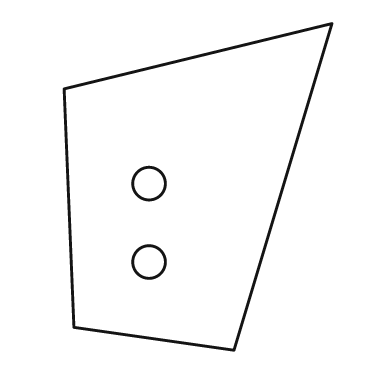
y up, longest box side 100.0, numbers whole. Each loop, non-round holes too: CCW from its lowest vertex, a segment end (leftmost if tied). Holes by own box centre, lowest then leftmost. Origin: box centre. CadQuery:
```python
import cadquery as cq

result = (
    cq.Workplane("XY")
    .moveTo(11.0, -50.0)
    .lineTo(41.0, 50.0)
    .lineTo(-41.0, 30.0)
    .lineTo(-38.0, -43.0)
    .close()
    .moveTo(-15.0, -23.0)
    .circle(5.0)
    .moveTo(-15.0, 1.0)
    .circle(5.0)
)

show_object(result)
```